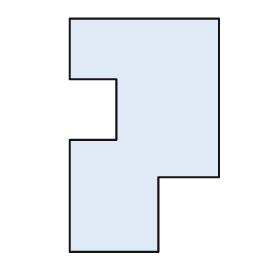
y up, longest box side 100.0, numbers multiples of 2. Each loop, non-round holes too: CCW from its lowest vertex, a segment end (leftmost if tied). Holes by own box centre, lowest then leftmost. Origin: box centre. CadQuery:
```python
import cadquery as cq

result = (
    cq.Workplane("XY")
    .moveTo(-32.0, -50.0)
    .lineTo(6.0, -50.0)
    .lineTo(6.0, -18.0)
    .lineTo(32.0, -18.0)
    .lineTo(32.0, 50.0)
    .lineTo(-32.0, 50.0)
    .lineTo(-32.0, 24.0)
    .lineTo(-12.0, 24.0)
    .lineTo(-12.0, -2.0)
    .lineTo(-32.0, -2.0)
    .close()
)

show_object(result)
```